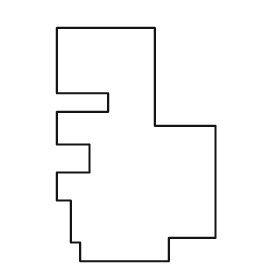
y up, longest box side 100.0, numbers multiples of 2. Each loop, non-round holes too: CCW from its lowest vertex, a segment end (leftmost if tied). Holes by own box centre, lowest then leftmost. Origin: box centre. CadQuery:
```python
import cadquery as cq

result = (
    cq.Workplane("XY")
    .moveTo(-24.0, -50.0)
    .lineTo(14.0, -50.0)
    .lineTo(14.0, -40.0)
    .lineTo(34.0, -40.0)
    .lineTo(34.0, 8.0)
    .lineTo(8.0, 8.0)
    .lineTo(8.0, 50.0)
    .lineTo(-34.0, 50.0)
    .lineTo(-34.0, 22.0)
    .lineTo(-12.0, 22.0)
    .lineTo(-12.0, 14.0)
    .lineTo(-34.0, 14.0)
    .lineTo(-34.0, 0.0)
    .lineTo(-20.0, 0.0)
    .lineTo(-20.0, -12.0)
    .lineTo(-34.0, -12.0)
    .lineTo(-34.0, -24.0)
    .lineTo(-28.0, -24.0)
    .lineTo(-28.0, -42.0)
    .lineTo(-24.0, -42.0)
    .close()
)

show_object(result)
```